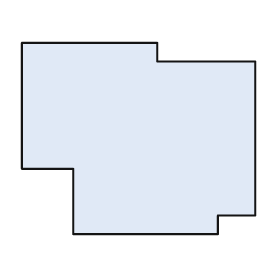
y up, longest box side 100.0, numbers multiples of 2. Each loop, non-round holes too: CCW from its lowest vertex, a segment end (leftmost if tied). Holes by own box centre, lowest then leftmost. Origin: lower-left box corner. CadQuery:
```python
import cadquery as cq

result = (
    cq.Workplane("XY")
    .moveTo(22.0, 0.0)
    .lineTo(84.0, 0.0)
    .lineTo(84.0, 8.0)
    .lineTo(100.0, 8.0)
    .lineTo(100.0, 74.0)
    .lineTo(58.0, 74.0)
    .lineTo(58.0, 82.0)
    .lineTo(0.0, 82.0)
    .lineTo(0.0, 28.0)
    .lineTo(22.0, 28.0)
    .close()
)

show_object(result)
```